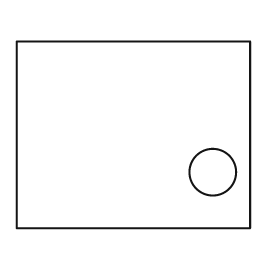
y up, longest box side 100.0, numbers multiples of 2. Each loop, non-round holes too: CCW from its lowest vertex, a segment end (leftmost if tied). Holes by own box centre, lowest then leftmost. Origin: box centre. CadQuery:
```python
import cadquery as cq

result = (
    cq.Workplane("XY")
    .moveTo(-50.0, -40.0)
    .lineTo(50.0, -40.0)
    .lineTo(50.0, 40.0)
    .lineTo(-50.0, 40.0)
    .close()
    .moveTo(34.0, -16.0)
    .circle(10.0)
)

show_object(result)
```